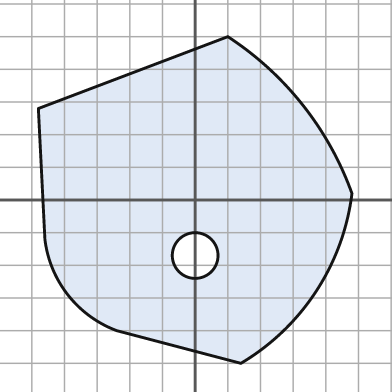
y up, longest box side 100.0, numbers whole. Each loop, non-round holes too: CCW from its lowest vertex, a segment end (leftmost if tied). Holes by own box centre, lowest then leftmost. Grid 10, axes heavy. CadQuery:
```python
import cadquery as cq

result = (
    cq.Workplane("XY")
    .moveTo(14.0, -50.0)
    .threePointArc((37.0, -28.0), (48.0, 2.0))
    .threePointArc((33.0, 29.0), (10.0, 50.0))
    .lineTo(-48.0, 28.0)
    .lineTo(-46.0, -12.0)
    .threePointArc((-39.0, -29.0), (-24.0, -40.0))
    .close()
    .moveTo(0.0, -17.0)
    .circle(7.0)
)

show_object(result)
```